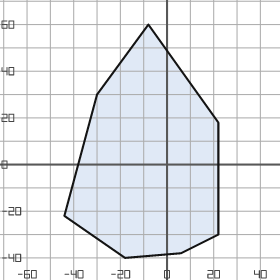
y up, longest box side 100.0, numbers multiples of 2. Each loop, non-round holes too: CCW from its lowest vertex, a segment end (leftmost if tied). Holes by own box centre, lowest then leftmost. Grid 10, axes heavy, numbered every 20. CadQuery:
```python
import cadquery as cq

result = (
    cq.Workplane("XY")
    .moveTo(-18.0, -40.0)
    .lineTo(6.0, -38.0)
    .lineTo(22.0, -30.0)
    .lineTo(22.0, 18.0)
    .lineTo(-8.0, 60.0)
    .lineTo(-30.0, 30.0)
    .lineTo(-44.0, -22.0)
    .close()
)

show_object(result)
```